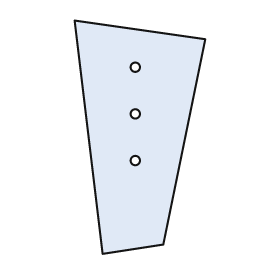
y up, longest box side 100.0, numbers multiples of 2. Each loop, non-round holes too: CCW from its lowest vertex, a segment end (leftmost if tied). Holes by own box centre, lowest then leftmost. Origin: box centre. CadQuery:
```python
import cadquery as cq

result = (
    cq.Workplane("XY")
    .moveTo(-16.0, -50.0)
    .lineTo(10.0, -46.0)
    .lineTo(28.0, 42.0)
    .lineTo(-28.0, 50.0)
    .close()
    .moveTo(-2.0, -10.0)
    .circle(2.0)
    .moveTo(-2.0, 10.0)
    .circle(2.0)
    .moveTo(-2.0, 30.0)
    .circle(2.0)
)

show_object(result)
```